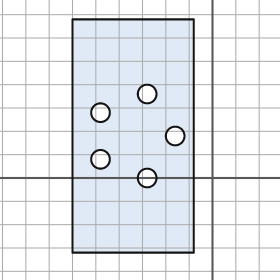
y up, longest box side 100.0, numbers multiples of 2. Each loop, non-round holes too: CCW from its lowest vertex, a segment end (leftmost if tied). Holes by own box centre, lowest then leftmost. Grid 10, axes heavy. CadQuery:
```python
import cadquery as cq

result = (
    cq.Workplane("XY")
    .moveTo(-60.0, -32.0)
    .lineTo(-8.0, -32.0)
    .lineTo(-8.0, 68.0)
    .lineTo(-60.0, 68.0)
    .close()
    .moveTo(-28.0, 0.0)
    .circle(4.0)
    .moveTo(-48.0, 8.0)
    .circle(4.0)
    .moveTo(-16.0, 18.0)
    .circle(4.0)
    .moveTo(-48.0, 28.0)
    .circle(4.0)
    .moveTo(-28.0, 36.0)
    .circle(4.0)
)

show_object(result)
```